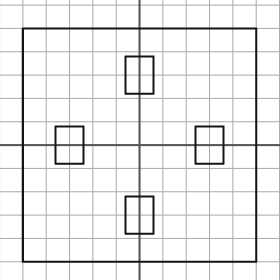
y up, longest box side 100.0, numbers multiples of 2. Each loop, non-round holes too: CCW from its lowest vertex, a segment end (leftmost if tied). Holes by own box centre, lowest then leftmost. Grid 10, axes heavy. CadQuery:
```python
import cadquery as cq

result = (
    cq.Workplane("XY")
    .moveTo(-50.0, -50.0)
    .lineTo(50.0, -50.0)
    .lineTo(50.0, 50.0)
    .lineTo(-50.0, 50.0)
    .close()
    .moveTo(-6.0, -38.0)
    .lineTo(6.0, -38.0)
    .lineTo(6.0, -22.0)
    .lineTo(-6.0, -22.0)
    .close()
    .moveTo(-36.0, -8.0)
    .lineTo(-24.0, -8.0)
    .lineTo(-24.0, 8.0)
    .lineTo(-36.0, 8.0)
    .close()
    .moveTo(24.0, -8.0)
    .lineTo(36.0, -8.0)
    .lineTo(36.0, 8.0)
    .lineTo(24.0, 8.0)
    .close()
    .moveTo(-6.0, 22.0)
    .lineTo(6.0, 22.0)
    .lineTo(6.0, 38.0)
    .lineTo(-6.0, 38.0)
    .close()
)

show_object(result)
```